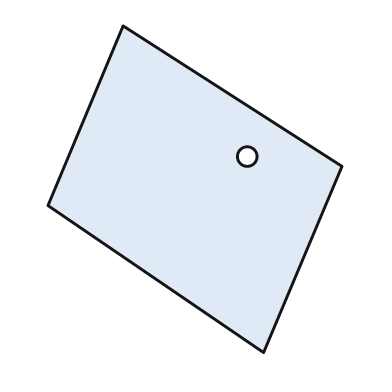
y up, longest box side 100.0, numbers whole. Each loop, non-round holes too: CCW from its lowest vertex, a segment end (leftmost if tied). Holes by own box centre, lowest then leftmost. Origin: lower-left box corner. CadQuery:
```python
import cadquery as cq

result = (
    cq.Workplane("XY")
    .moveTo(66.0, 0.0)
    .lineTo(90.0, 57.0)
    .lineTo(23.0, 100.0)
    .lineTo(0.0, 45.0)
    .close()
    .moveTo(61.0, 60.0)
    .circle(3.0)
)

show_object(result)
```